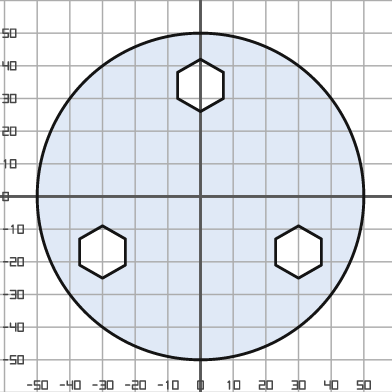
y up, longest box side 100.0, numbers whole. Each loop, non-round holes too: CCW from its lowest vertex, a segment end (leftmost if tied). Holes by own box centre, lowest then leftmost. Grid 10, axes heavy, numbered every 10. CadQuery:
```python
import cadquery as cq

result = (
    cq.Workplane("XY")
    .moveTo(0.0, 0.0)
    .circle(50.0)
    .moveTo(-30.0, -25.0)
    .lineTo(-23.0, -21.0)
    .lineTo(-23.0, -13.0)
    .lineTo(-30.0, -9.0)
    .lineTo(-37.0, -13.0)
    .lineTo(-37.0, -21.0)
    .close()
    .moveTo(30.0, -25.0)
    .lineTo(37.0, -21.0)
    .lineTo(37.0, -13.0)
    .lineTo(30.0, -9.0)
    .lineTo(23.0, -13.0)
    .lineTo(23.0, -21.0)
    .close()
    .moveTo(0.0, 26.0)
    .lineTo(7.0, 30.0)
    .lineTo(7.0, 38.0)
    .lineTo(0.0, 42.0)
    .lineTo(-7.0, 38.0)
    .lineTo(-7.0, 30.0)
    .close()
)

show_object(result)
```